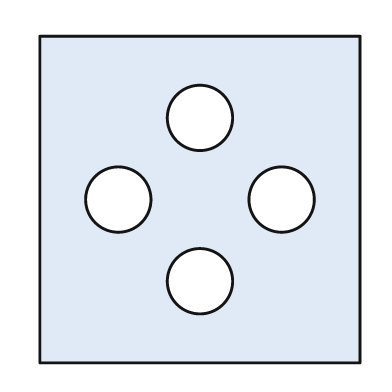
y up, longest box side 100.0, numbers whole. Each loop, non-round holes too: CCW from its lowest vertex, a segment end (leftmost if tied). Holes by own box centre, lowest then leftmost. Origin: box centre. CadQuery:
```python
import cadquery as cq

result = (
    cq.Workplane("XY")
    .moveTo(-49.0, -50.0)
    .lineTo(49.0, -50.0)
    .lineTo(49.0, 50.0)
    .lineTo(-49.0, 50.0)
    .close()
    .moveTo(0.0, -25.0)
    .circle(10.0)
    .moveTo(-25.0, 0.0)
    .circle(10.0)
    .moveTo(25.0, 0.0)
    .circle(10.0)
    .moveTo(0.0, 25.0)
    .circle(10.0)
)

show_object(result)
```